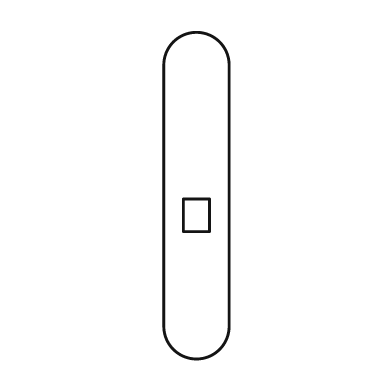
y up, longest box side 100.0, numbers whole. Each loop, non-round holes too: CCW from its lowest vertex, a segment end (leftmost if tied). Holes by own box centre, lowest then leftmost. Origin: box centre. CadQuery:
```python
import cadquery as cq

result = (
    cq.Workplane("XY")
    .moveTo(-10.0, -40.0)
    .threePointArc((0.0, -50.0), (10.0, -40.0))
    .lineTo(10.0, 40.0)
    .threePointArc((0.0, 50.0), (-10.0, 40.0))
    .close()
    .moveTo(-4.0, -11.0)
    .lineTo(4.0, -11.0)
    .lineTo(4.0, -1.0)
    .lineTo(-4.0, -1.0)
    .close()
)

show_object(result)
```